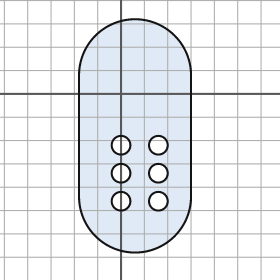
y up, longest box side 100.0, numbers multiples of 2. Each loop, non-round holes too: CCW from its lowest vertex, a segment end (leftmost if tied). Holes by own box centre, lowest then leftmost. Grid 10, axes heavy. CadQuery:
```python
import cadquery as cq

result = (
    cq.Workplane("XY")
    .moveTo(-18.0, -44.0)
    .threePointArc((6.0, -68.0), (30.0, -44.0))
    .lineTo(30.0, 8.0)
    .threePointArc((6.0, 32.0), (-18.0, 8.0))
    .close()
    .moveTo(0.0, -46.0)
    .circle(4.0)
    .moveTo(16.0, -46.0)
    .circle(4.0)
    .moveTo(0.0, -34.0)
    .circle(4.0)
    .moveTo(16.0, -34.0)
    .circle(4.0)
    .moveTo(0.0, -22.0)
    .circle(4.0)
    .moveTo(16.0, -22.0)
    .circle(4.0)
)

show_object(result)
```